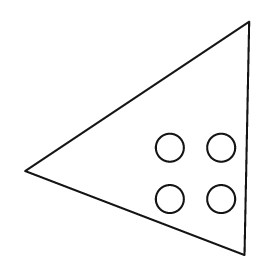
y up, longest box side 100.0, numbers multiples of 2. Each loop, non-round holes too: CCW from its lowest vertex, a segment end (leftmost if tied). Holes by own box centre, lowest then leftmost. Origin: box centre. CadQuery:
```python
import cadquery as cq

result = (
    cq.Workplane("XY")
    .moveTo(46.0, -50.0)
    .lineTo(48.0, 50.0)
    .lineTo(-48.0, -14.0)
    .close()
    .moveTo(14.0, -26.0)
    .circle(6.0)
    .moveTo(36.0, -26.0)
    .circle(6.0)
    .moveTo(14.0, -4.0)
    .circle(6.0)
    .moveTo(36.0, -4.0)
    .circle(6.0)
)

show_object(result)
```